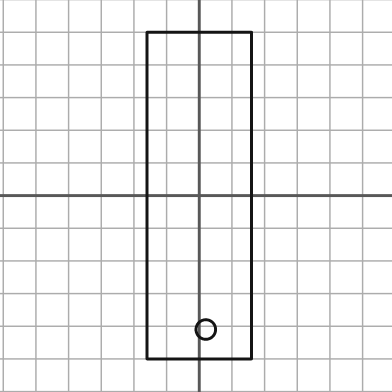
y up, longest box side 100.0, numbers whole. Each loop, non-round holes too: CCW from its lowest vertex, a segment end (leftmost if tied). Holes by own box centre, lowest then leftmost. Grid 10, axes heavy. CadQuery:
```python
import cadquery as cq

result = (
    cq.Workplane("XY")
    .moveTo(-16.0, -50.0)
    .lineTo(16.0, -50.0)
    .lineTo(16.0, 50.0)
    .lineTo(-16.0, 50.0)
    .close()
    .moveTo(2.0, -41.0)
    .circle(3.0)
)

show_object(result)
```